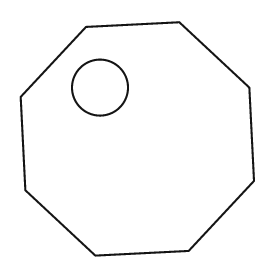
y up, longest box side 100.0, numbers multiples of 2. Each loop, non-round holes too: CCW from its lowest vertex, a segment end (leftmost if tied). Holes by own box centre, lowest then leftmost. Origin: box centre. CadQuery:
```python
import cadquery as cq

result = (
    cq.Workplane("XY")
    .moveTo(-18.0, -50.0)
    .lineTo(22.0, -48.0)
    .lineTo(50.0, -18.0)
    .lineTo(48.0, 22.0)
    .lineTo(18.0, 50.0)
    .lineTo(-22.0, 48.0)
    .lineTo(-50.0, 18.0)
    .lineTo(-48.0, -22.0)
    .close()
    .moveTo(-16.0, 22.0)
    .circle(12.0)
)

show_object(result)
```